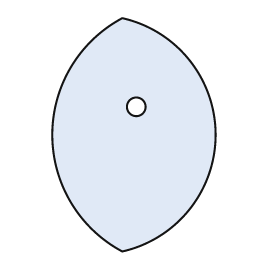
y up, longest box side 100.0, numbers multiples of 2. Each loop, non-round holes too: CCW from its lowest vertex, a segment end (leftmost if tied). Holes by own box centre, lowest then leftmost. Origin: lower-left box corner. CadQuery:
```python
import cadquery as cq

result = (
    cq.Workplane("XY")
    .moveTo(30.0, 0.0)
    .threePointArc((70.0, 50.0), (30.0, 100.0))
    .threePointArc((0.0, 50.0), (30.0, 0.0))
    .close()
    .moveTo(36.0, 62.0)
    .circle(4.0)
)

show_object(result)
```